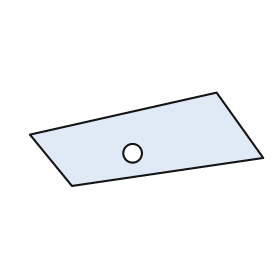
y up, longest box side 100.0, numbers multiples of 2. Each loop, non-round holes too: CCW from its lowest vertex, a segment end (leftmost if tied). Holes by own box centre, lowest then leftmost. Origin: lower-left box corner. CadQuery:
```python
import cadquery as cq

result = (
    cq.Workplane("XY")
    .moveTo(18.0, 0.0)
    .lineTo(100.0, 12.0)
    .lineTo(80.0, 40.0)
    .lineTo(0.0, 22.0)
    .close()
    .moveTo(44.0, 14.0)
    .circle(4.0)
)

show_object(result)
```